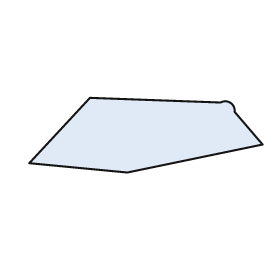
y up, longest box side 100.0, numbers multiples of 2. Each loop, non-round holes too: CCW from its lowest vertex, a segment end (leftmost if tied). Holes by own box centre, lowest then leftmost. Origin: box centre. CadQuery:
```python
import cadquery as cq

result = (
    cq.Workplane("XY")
    .moveTo(-8.0, -16.0)
    .lineTo(50.0, -4.0)
    .lineTo(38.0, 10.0)
    .threePointArc((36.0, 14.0), (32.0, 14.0))
    .lineTo(-24.0, 16.0)
    .lineTo(-50.0, -12.0)
    .close()
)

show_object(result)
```